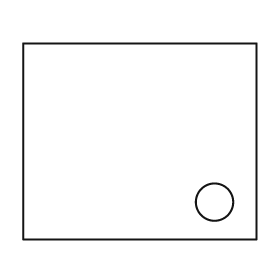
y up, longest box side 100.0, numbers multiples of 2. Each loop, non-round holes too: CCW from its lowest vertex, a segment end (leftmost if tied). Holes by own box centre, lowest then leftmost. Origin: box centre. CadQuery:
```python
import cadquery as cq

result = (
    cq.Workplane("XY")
    .moveTo(-50.0, -42.0)
    .lineTo(50.0, -42.0)
    .lineTo(50.0, 42.0)
    .lineTo(-50.0, 42.0)
    .close()
    .moveTo(32.0, -26.0)
    .circle(8.0)
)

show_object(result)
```